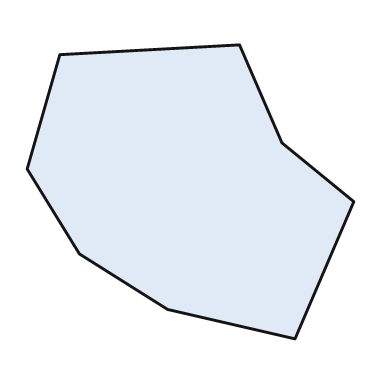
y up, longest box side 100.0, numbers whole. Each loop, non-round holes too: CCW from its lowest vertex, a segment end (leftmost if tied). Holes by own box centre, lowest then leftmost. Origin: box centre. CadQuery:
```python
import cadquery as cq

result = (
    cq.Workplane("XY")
    .moveTo(32.0, -45.0)
    .lineTo(50.0, -3.0)
    .lineTo(28.0, 15.0)
    .lineTo(15.0, 45.0)
    .lineTo(-40.0, 42.0)
    .lineTo(-50.0, 7.0)
    .lineTo(-34.0, -19.0)
    .lineTo(-7.0, -36.0)
    .close()
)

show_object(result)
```